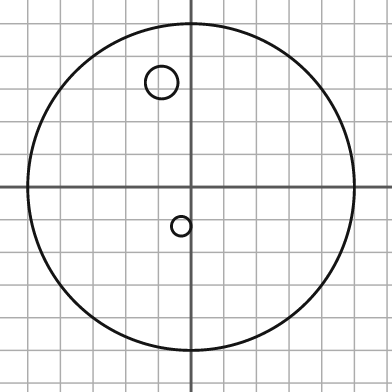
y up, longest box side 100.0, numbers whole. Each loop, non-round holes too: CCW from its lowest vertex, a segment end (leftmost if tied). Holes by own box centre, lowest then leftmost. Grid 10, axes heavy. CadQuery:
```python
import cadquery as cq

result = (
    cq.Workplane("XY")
    .moveTo(0.0, 0.0)
    .circle(50.0)
    .moveTo(-3.0, -12.0)
    .circle(3.0)
    .moveTo(-9.0, 32.0)
    .circle(5.0)
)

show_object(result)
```